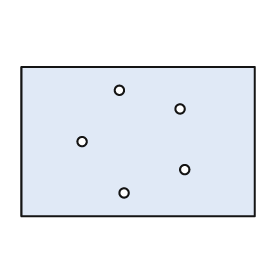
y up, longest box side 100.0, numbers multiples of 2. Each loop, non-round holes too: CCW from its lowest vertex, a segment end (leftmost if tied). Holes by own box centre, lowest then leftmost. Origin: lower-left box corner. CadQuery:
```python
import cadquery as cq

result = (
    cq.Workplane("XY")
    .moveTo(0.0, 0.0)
    .lineTo(100.0, 0.0)
    .lineTo(100.0, 64.0)
    .lineTo(0.0, 64.0)
    .close()
    .moveTo(44.0, 10.0)
    .circle(2.0)
    .moveTo(70.0, 20.0)
    .circle(2.0)
    .moveTo(26.0, 32.0)
    .circle(2.0)
    .moveTo(68.0, 46.0)
    .circle(2.0)
    .moveTo(42.0, 54.0)
    .circle(2.0)
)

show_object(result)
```